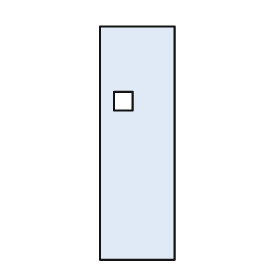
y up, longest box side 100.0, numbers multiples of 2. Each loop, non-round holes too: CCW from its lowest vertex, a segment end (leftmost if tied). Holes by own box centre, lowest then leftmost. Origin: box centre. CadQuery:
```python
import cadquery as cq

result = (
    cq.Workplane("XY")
    .moveTo(-16.0, -50.0)
    .lineTo(16.0, -50.0)
    .lineTo(16.0, 50.0)
    .lineTo(-16.0, 50.0)
    .close()
    .moveTo(-10.0, 14.0)
    .lineTo(-2.0, 14.0)
    .lineTo(-2.0, 22.0)
    .lineTo(-10.0, 22.0)
    .close()
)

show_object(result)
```